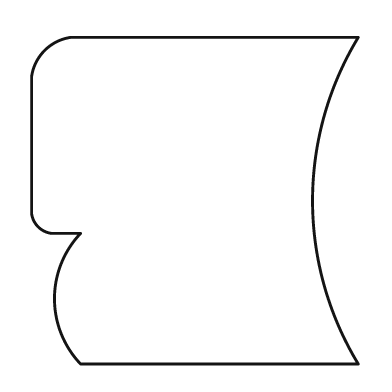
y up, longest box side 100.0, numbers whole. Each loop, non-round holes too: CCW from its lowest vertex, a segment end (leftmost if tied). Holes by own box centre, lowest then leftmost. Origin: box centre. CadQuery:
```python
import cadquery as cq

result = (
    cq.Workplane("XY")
    .moveTo(-35.0, -50.0)
    .lineTo(50.0, -50.0)
    .threePointArc((36.0, 0.0), (50.0, 50.0))
    .lineTo(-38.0, 50.0)
    .threePointArc((-46.0, 46.0), (-50.0, 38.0))
    .lineTo(-50.0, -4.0)
    .threePointArc((-48.0, -8.0), (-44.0, -10.0))
    .lineTo(-35.0, -10.0)
    .threePointArc((-43.0, -30.0), (-35.0, -50.0))
    .close()
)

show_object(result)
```